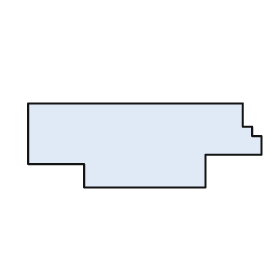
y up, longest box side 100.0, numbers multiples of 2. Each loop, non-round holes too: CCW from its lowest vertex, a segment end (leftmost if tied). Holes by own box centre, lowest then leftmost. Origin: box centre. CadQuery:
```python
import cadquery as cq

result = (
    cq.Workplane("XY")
    .moveTo(-26.0, -18.0)
    .lineTo(26.0, -18.0)
    .lineTo(26.0, -4.0)
    .lineTo(50.0, -4.0)
    .lineTo(50.0, 4.0)
    .lineTo(46.0, 4.0)
    .lineTo(46.0, 8.0)
    .lineTo(42.0, 8.0)
    .lineTo(42.0, 18.0)
    .lineTo(-50.0, 18.0)
    .lineTo(-50.0, -8.0)
    .lineTo(-26.0, -8.0)
    .close()
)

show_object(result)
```